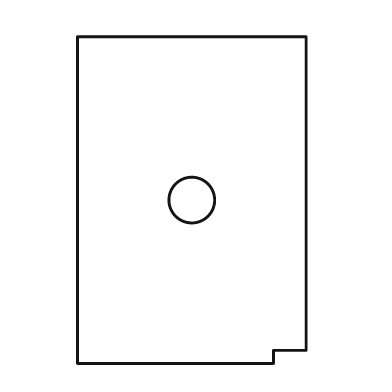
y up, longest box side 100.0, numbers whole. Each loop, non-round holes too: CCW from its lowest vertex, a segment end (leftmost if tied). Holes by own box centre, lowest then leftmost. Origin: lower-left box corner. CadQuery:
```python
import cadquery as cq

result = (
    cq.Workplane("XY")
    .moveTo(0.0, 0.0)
    .lineTo(60.0, 0.0)
    .lineTo(60.0, 4.0)
    .lineTo(70.0, 4.0)
    .lineTo(70.0, 100.0)
    .lineTo(0.0, 100.0)
    .close()
    .moveTo(35.0, 50.0)
    .circle(7.0)
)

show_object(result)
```